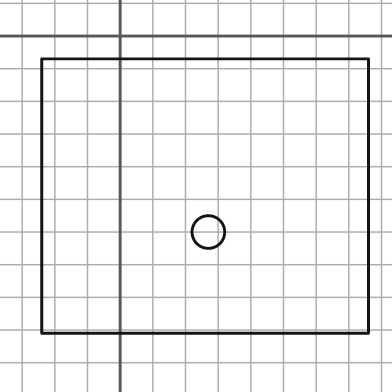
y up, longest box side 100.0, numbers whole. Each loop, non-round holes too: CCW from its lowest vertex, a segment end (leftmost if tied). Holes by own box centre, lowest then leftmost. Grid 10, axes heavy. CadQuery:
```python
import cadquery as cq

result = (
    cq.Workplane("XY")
    .moveTo(-24.0, -91.0)
    .lineTo(76.0, -91.0)
    .lineTo(76.0, -7.0)
    .lineTo(-24.0, -7.0)
    .close()
    .moveTo(27.0, -60.0)
    .circle(5.0)
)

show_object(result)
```